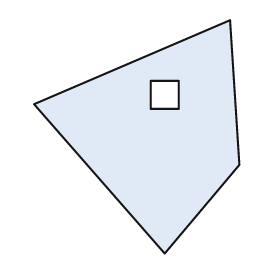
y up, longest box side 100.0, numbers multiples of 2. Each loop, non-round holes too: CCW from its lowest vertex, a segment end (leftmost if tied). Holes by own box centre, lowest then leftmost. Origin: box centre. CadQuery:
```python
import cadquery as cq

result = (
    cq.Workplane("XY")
    .moveTo(12.0, -50.0)
    .lineTo(44.0, -12.0)
    .lineTo(40.0, 50.0)
    .lineTo(-44.0, 14.0)
    .close()
    .moveTo(6.0, 12.0)
    .lineTo(18.0, 12.0)
    .lineTo(18.0, 24.0)
    .lineTo(6.0, 24.0)
    .close()
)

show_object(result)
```